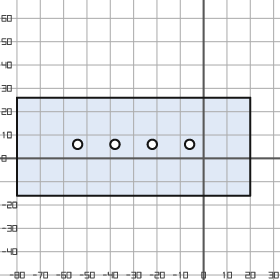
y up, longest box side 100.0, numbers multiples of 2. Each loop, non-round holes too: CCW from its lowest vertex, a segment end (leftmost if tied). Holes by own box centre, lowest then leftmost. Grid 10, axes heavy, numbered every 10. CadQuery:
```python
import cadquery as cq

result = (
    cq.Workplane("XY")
    .moveTo(-80.0, -16.0)
    .lineTo(20.0, -16.0)
    .lineTo(20.0, 26.0)
    .lineTo(-80.0, 26.0)
    .close()
    .moveTo(-54.0, 6.0)
    .circle(2.0)
    .moveTo(-38.0, 6.0)
    .circle(2.0)
    .moveTo(-22.0, 6.0)
    .circle(2.0)
    .moveTo(-6.0, 6.0)
    .circle(2.0)
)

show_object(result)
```